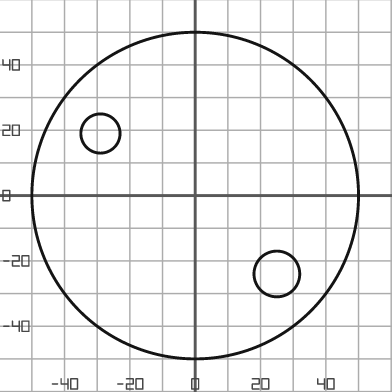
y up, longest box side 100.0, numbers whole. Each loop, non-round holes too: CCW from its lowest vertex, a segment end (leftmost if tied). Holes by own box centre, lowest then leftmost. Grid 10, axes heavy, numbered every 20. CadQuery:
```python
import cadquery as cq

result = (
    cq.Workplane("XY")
    .moveTo(0.0, 0.0)
    .circle(50.0)
    .moveTo(25.0, -24.0)
    .circle(7.0)
    .moveTo(-29.0, 19.0)
    .circle(6.0)
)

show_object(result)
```